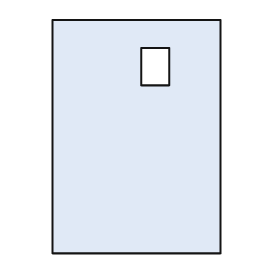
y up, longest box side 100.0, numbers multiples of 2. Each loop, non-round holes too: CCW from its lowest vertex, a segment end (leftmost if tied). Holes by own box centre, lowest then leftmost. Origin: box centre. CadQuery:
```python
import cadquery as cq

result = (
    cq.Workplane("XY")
    .moveTo(-36.0, -50.0)
    .lineTo(36.0, -50.0)
    .lineTo(36.0, 50.0)
    .lineTo(-36.0, 50.0)
    .close()
    .moveTo(2.0, 22.0)
    .lineTo(14.0, 22.0)
    .lineTo(14.0, 38.0)
    .lineTo(2.0, 38.0)
    .close()
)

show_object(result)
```